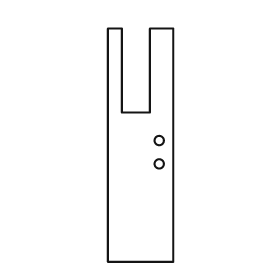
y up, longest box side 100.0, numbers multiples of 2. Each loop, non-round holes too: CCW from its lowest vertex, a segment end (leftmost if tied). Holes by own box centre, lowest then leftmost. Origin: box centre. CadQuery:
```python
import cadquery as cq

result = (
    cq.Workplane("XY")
    .moveTo(-14.0, -50.0)
    .lineTo(14.0, -50.0)
    .lineTo(14.0, 50.0)
    .lineTo(4.0, 50.0)
    .lineTo(4.0, 14.0)
    .lineTo(-8.0, 14.0)
    .lineTo(-8.0, 50.0)
    .lineTo(-14.0, 50.0)
    .close()
    .moveTo(8.0, -8.0)
    .circle(2.0)
    .moveTo(8.0, 2.0)
    .circle(2.0)
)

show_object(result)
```